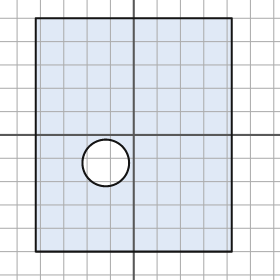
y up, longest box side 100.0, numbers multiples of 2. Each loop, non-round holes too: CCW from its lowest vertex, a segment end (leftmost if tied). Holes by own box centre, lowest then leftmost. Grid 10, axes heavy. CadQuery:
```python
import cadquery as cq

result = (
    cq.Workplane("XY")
    .moveTo(-42.0, -50.0)
    .lineTo(42.0, -50.0)
    .lineTo(42.0, 50.0)
    .lineTo(-42.0, 50.0)
    .close()
    .moveTo(-12.0, -12.0)
    .circle(10.0)
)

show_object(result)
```